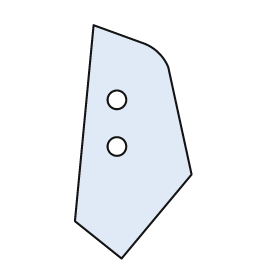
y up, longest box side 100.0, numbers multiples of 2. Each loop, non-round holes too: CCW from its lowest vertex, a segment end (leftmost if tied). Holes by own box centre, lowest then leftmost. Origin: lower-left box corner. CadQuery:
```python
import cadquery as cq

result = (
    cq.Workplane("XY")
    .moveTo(20.0, 0.0)
    .lineTo(50.0, 36.0)
    .lineTo(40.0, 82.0)
    .threePointArc((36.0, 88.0), (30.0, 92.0))
    .lineTo(8.0, 100.0)
    .lineTo(0.0, 16.0)
    .close()
    .moveTo(18.0, 48.0)
    .circle(4.0)
    .moveTo(18.0, 68.0)
    .circle(4.0)
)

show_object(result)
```